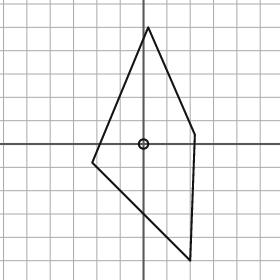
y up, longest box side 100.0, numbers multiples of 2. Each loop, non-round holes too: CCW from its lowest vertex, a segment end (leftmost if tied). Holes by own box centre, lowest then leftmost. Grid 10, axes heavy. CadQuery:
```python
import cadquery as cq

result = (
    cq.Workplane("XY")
    .moveTo(20.0, -50.0)
    .lineTo(22.0, 4.0)
    .lineTo(2.0, 50.0)
    .lineTo(-22.0, -8.0)
    .close()
    .moveTo(0.0, 0.0)
    .circle(2.0)
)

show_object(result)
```